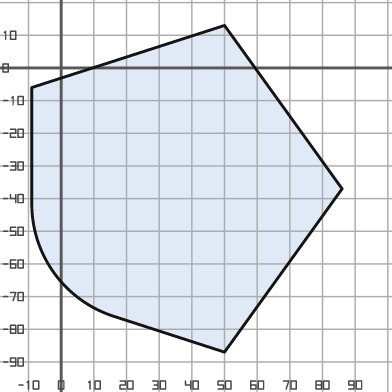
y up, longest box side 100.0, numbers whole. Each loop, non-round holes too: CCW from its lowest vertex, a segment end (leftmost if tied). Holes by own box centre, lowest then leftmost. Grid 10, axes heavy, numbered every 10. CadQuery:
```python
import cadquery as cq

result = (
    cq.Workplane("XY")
    .moveTo(50.0, -87.0)
    .lineTo(86.0, -37.0)
    .lineTo(50.0, 13.0)
    .lineTo(-9.0, -6.0)
    .lineTo(-9.0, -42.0)
    .threePointArc((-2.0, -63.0), (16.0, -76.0))
    .close()
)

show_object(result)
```